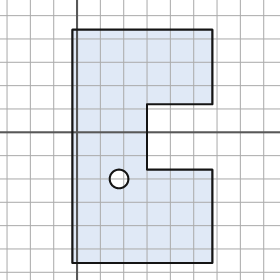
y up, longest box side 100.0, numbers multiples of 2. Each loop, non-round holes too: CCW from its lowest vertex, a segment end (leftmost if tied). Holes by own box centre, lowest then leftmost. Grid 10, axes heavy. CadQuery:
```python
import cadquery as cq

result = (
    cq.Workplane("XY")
    .moveTo(-2.0, -56.0)
    .lineTo(58.0, -56.0)
    .lineTo(58.0, -16.0)
    .lineTo(30.0, -16.0)
    .lineTo(30.0, 12.0)
    .lineTo(58.0, 12.0)
    .lineTo(58.0, 44.0)
    .lineTo(-2.0, 44.0)
    .close()
    .moveTo(18.0, -20.0)
    .circle(4.0)
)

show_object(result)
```